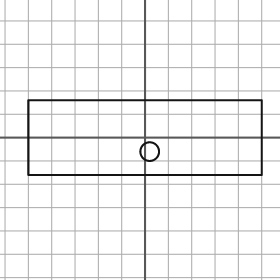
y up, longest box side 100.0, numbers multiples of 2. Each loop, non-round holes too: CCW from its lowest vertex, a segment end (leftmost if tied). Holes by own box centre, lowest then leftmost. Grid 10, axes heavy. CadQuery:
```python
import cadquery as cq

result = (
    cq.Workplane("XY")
    .moveTo(-50.0, -16.0)
    .lineTo(50.0, -16.0)
    .lineTo(50.0, 16.0)
    .lineTo(-50.0, 16.0)
    .close()
    .moveTo(2.0, -6.0)
    .circle(4.0)
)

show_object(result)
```